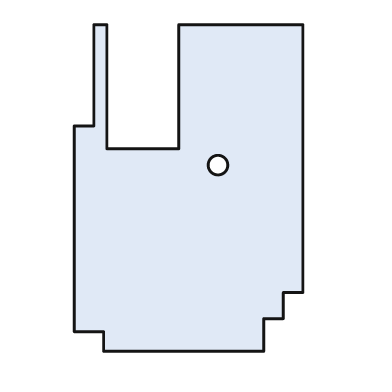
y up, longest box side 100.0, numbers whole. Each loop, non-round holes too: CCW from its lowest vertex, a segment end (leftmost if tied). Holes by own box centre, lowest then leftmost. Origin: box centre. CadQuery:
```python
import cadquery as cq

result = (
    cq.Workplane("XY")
    .moveTo(-26.0, -50.0)
    .lineTo(23.0, -50.0)
    .lineTo(23.0, -40.0)
    .lineTo(29.0, -40.0)
    .lineTo(29.0, -32.0)
    .lineTo(35.0, -32.0)
    .lineTo(35.0, 50.0)
    .lineTo(-3.0, 50.0)
    .lineTo(-3.0, 12.0)
    .lineTo(-25.0, 12.0)
    .lineTo(-25.0, 50.0)
    .lineTo(-29.0, 50.0)
    .lineTo(-29.0, 19.0)
    .lineTo(-35.0, 19.0)
    .lineTo(-35.0, -44.0)
    .lineTo(-26.0, -44.0)
    .close()
    .moveTo(9.0, 7.0)
    .circle(3.0)
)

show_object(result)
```